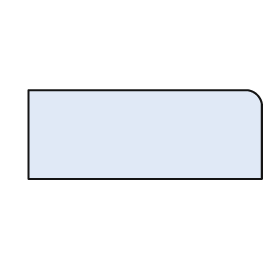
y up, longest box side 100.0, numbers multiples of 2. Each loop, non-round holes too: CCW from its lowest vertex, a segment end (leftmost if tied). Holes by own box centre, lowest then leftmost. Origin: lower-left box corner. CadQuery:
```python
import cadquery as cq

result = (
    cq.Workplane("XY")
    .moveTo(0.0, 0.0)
    .lineTo(100.0, 0.0)
    .lineTo(100.0, 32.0)
    .threePointArc((98.0, 36.0), (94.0, 38.0))
    .lineTo(0.0, 38.0)
    .close()
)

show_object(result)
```